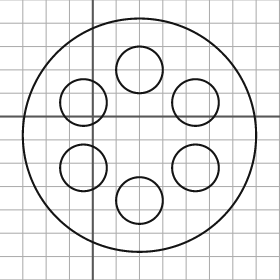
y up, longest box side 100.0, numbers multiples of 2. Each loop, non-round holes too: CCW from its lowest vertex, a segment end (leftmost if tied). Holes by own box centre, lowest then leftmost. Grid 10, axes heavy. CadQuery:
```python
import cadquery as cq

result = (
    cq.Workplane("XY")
    .moveTo(20.0, -8.0)
    .circle(50.0)
    .moveTo(20.0, -36.0)
    .circle(10.0)
    .moveTo(-4.0, -22.0)
    .circle(10.0)
    .moveTo(44.0, -22.0)
    .circle(10.0)
    .moveTo(-4.0, 6.0)
    .circle(10.0)
    .moveTo(44.0, 6.0)
    .circle(10.0)
    .moveTo(20.0, 20.0)
    .circle(10.0)
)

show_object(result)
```